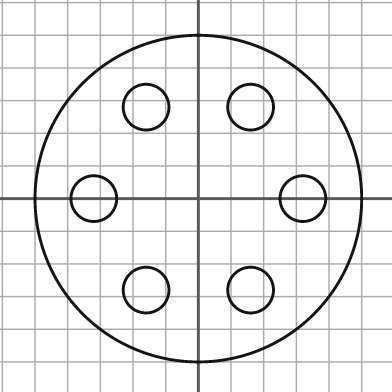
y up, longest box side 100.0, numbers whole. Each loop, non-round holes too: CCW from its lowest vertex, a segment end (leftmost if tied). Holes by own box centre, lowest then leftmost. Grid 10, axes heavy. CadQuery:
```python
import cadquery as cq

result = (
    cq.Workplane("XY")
    .moveTo(0.0, 0.0)
    .circle(50.0)
    .moveTo(-16.0, -28.0)
    .circle(7.0)
    .moveTo(16.0, -28.0)
    .circle(7.0)
    .moveTo(-32.0, 0.0)
    .circle(7.0)
    .moveTo(32.0, 0.0)
    .circle(7.0)
    .moveTo(-16.0, 28.0)
    .circle(7.0)
    .moveTo(16.0, 28.0)
    .circle(7.0)
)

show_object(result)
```